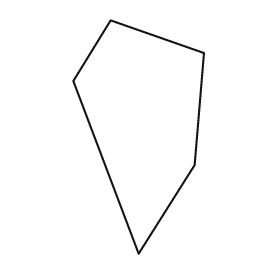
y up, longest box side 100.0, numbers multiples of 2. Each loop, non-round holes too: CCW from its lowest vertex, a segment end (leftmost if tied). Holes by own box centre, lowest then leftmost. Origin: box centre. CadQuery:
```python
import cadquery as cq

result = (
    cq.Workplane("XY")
    .moveTo(0.0, -50.0)
    .lineTo(24.0, -12.0)
    .lineTo(28.0, 36.0)
    .lineTo(-12.0, 50.0)
    .lineTo(-28.0, 24.0)
    .close()
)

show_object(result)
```